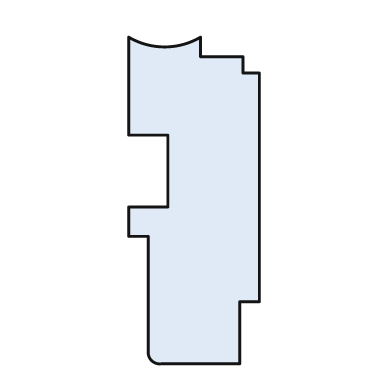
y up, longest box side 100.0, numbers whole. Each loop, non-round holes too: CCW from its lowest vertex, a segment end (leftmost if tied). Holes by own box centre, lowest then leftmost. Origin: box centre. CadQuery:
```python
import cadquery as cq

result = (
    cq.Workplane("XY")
    .moveTo(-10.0, -50.0)
    .lineTo(14.0, -50.0)
    .lineTo(14.0, -31.0)
    .lineTo(20.0, -31.0)
    .lineTo(20.0, 39.0)
    .lineTo(15.0, 39.0)
    .lineTo(15.0, 44.0)
    .lineTo(2.0, 44.0)
    .lineTo(2.0, 50.0)
    .threePointArc((-9.0, 47.0), (-20.0, 50.0))
    .lineTo(-20.0, 20.0)
    .lineTo(-8.0, 20.0)
    .lineTo(-8.0, -2.0)
    .lineTo(-20.0, -2.0)
    .lineTo(-20.0, -11.0)
    .lineTo(-14.0, -11.0)
    .lineTo(-14.0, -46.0)
    .threePointArc((-13.0, -49.0), (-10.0, -50.0))
    .close()
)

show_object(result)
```